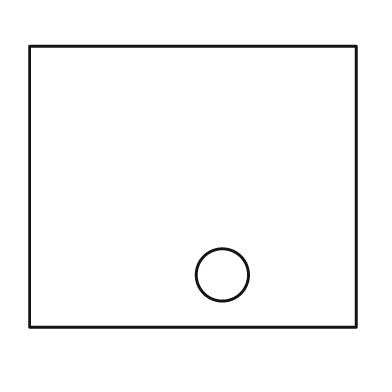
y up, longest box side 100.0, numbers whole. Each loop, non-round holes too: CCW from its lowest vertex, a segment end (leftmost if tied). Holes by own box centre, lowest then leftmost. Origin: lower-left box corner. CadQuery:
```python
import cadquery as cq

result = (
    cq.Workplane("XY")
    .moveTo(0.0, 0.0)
    .lineTo(100.0, 0.0)
    .lineTo(100.0, 86.0)
    .lineTo(0.0, 86.0)
    .close()
    .moveTo(59.0, 16.0)
    .circle(8.0)
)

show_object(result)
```